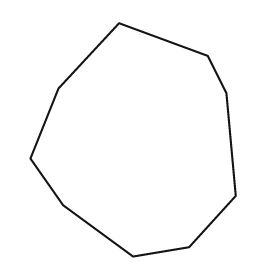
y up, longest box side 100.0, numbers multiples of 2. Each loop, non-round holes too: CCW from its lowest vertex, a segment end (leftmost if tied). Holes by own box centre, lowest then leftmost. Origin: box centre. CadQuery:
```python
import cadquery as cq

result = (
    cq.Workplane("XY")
    .moveTo(0.0, -50.0)
    .lineTo(24.0, -46.0)
    .lineTo(44.0, -24.0)
    .lineTo(40.0, 20.0)
    .lineTo(32.0, 36.0)
    .lineTo(-6.0, 50.0)
    .lineTo(-32.0, 22.0)
    .lineTo(-44.0, -8.0)
    .lineTo(-30.0, -28.0)
    .close()
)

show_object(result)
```